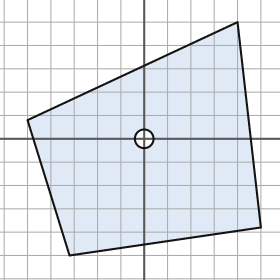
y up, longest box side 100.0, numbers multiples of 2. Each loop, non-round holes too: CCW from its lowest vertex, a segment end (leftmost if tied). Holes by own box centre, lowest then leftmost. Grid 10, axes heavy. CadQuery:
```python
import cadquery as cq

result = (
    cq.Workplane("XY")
    .moveTo(-32.0, -50.0)
    .lineTo(50.0, -38.0)
    .lineTo(40.0, 50.0)
    .lineTo(-50.0, 8.0)
    .close()
    .moveTo(0.0, 0.0)
    .circle(4.0)
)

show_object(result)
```